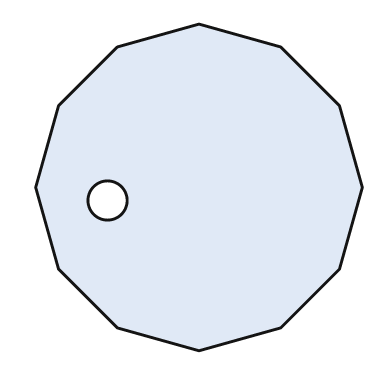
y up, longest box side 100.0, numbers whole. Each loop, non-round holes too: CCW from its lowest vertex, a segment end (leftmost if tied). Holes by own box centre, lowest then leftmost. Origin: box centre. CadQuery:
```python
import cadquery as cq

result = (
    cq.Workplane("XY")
    .moveTo(0.0, -50.0)
    .lineTo(25.0, -43.0)
    .lineTo(43.0, -25.0)
    .lineTo(50.0, 0.0)
    .lineTo(43.0, 25.0)
    .lineTo(25.0, 43.0)
    .lineTo(0.0, 50.0)
    .lineTo(-25.0, 43.0)
    .lineTo(-43.0, 25.0)
    .lineTo(-50.0, 0.0)
    .lineTo(-43.0, -25.0)
    .lineTo(-25.0, -43.0)
    .close()
    .moveTo(-28.0, -4.0)
    .circle(6.0)
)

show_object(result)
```